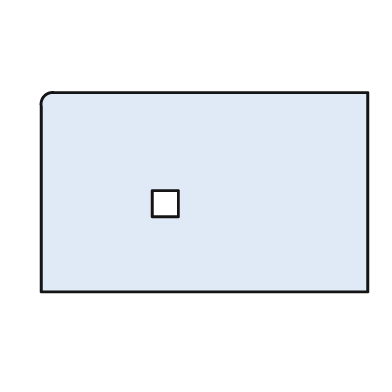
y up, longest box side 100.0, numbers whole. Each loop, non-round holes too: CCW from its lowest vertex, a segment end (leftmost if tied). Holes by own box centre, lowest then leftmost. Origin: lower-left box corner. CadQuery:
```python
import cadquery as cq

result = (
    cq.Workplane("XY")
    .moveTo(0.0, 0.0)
    .lineTo(100.0, 0.0)
    .lineTo(100.0, 61.0)
    .lineTo(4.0, 61.0)
    .threePointArc((1.0, 60.0), (0.0, 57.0))
    .close()
    .moveTo(34.0, 23.0)
    .lineTo(42.0, 23.0)
    .lineTo(42.0, 31.0)
    .lineTo(34.0, 31.0)
    .close()
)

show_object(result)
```